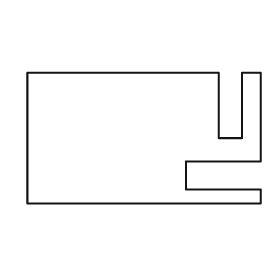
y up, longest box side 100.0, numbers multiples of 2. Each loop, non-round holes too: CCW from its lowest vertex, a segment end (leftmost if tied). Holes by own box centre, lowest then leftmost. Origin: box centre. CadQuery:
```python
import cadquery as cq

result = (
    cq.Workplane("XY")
    .moveTo(-50.0, -28.0)
    .lineTo(50.0, -28.0)
    .lineTo(50.0, -22.0)
    .lineTo(18.0, -22.0)
    .lineTo(18.0, -10.0)
    .lineTo(50.0, -10.0)
    .lineTo(50.0, 28.0)
    .lineTo(42.0, 28.0)
    .lineTo(42.0, 0.0)
    .lineTo(32.0, 0.0)
    .lineTo(32.0, 28.0)
    .lineTo(-50.0, 28.0)
    .close()
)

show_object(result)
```